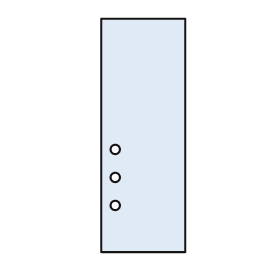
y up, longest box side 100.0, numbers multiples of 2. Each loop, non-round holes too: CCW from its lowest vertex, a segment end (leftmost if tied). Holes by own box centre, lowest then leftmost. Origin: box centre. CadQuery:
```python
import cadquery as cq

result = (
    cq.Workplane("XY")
    .moveTo(-18.0, -50.0)
    .lineTo(18.0, -50.0)
    .lineTo(18.0, 50.0)
    .lineTo(-18.0, 50.0)
    .close()
    .moveTo(-12.0, -30.0)
    .circle(2.0)
    .moveTo(-12.0, -18.0)
    .circle(2.0)
    .moveTo(-12.0, -6.0)
    .circle(2.0)
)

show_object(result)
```